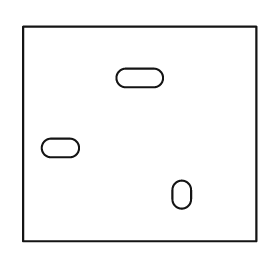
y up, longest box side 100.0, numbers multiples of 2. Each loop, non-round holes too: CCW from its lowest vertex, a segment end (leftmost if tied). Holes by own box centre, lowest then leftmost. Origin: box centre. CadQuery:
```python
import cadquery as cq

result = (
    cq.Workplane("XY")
    .moveTo(-50.0, -46.0)
    .lineTo(50.0, -46.0)
    .lineTo(50.0, 46.0)
    .lineTo(-50.0, 46.0)
    .close()
    .moveTo(14.0, -28.0)
    .threePointArc((18.0, -32.0), (22.0, -28.0))
    .lineTo(22.0, -24.0)
    .threePointArc((18.0, -20.0), (14.0, -24.0))
    .close()
    .moveTo(-38.0, -10.0)
    .lineTo(-30.0, -10.0)
    .threePointArc((-26.0, -6.0), (-30.0, -2.0))
    .lineTo(-38.0, -2.0)
    .threePointArc((-42.0, -6.0), (-38.0, -10.0))
    .close()
    .moveTo(-6.0, 20.0)
    .lineTo(6.0, 20.0)
    .threePointArc((10.0, 24.0), (6.0, 28.0))
    .lineTo(-6.0, 28.0)
    .threePointArc((-10.0, 24.0), (-6.0, 20.0))
    .close()
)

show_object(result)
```